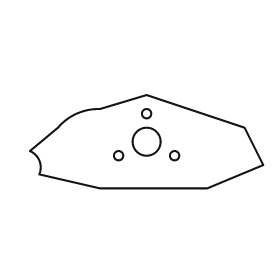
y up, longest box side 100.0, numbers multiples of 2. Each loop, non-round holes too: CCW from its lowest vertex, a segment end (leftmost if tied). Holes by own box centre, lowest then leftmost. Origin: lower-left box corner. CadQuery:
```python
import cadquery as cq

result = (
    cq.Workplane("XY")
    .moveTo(30.0, 0.0)
    .lineTo(76.0, 0.0)
    .lineTo(100.0, 10.0)
    .lineTo(92.0, 26.0)
    .lineTo(50.0, 40.0)
    .lineTo(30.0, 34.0)
    .threePointArc((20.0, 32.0), (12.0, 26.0))
    .lineTo(0.0, 16.0)
    .threePointArc((4.0, 12.0), (4.0, 6.0))
    .close()
    .moveTo(38.0, 14.0)
    .circle(2.0)
    .moveTo(62.0, 14.0)
    .circle(2.0)
    .moveTo(50.0, 20.0)
    .circle(6.0)
    .moveTo(50.0, 32.0)
    .circle(2.0)
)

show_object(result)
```